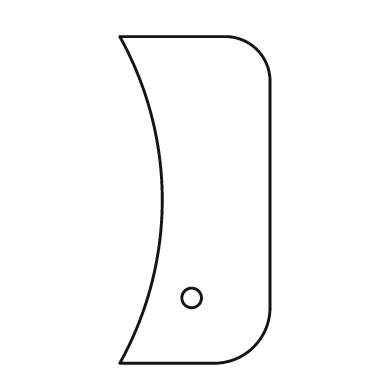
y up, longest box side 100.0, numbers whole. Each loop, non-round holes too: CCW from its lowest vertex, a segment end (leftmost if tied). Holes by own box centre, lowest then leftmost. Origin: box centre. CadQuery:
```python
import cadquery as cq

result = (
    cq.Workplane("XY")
    .moveTo(-23.0, -50.0)
    .lineTo(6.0, -50.0)
    .threePointArc((18.0, -45.0), (23.0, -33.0))
    .lineTo(23.0, 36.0)
    .threePointArc((19.0, 46.0), (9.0, 50.0))
    .lineTo(-23.0, 50.0)
    .threePointArc((-10.0, 0.0), (-23.0, -50.0))
    .close()
    .moveTo(-1.0, -30.0)
    .circle(3.0)
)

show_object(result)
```